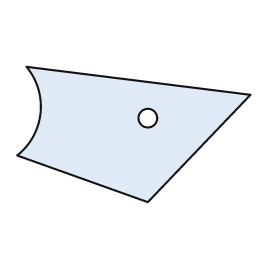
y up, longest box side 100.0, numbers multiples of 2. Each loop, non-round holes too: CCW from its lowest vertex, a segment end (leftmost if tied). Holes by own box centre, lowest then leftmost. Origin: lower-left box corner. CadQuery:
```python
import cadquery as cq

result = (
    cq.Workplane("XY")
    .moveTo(56.0, 0.0)
    .lineTo(100.0, 46.0)
    .lineTo(4.0, 58.0)
    .threePointArc((10.0, 38.0), (0.0, 20.0))
    .close()
    .moveTo(56.0, 36.0)
    .circle(4.0)
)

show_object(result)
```